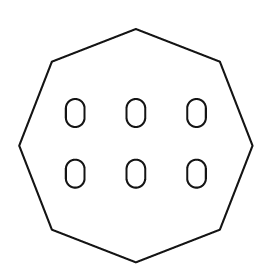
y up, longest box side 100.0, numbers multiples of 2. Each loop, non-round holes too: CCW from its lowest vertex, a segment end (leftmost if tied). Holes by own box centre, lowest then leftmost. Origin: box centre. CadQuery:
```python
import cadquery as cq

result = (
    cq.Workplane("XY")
    .moveTo(0.0, -50.0)
    .lineTo(36.0, -36.0)
    .lineTo(50.0, 0.0)
    .lineTo(36.0, 36.0)
    .lineTo(0.0, 50.0)
    .lineTo(-36.0, 36.0)
    .lineTo(-50.0, 0.0)
    .lineTo(-36.0, -36.0)
    .close()
    .moveTo(-30.0, -14.0)
    .threePointArc((-26.0, -18.0), (-22.0, -14.0))
    .lineTo(-22.0, -10.0)
    .threePointArc((-26.0, -6.0), (-30.0, -10.0))
    .close()
    .moveTo(-4.0, -14.0)
    .threePointArc((0.0, -18.0), (4.0, -14.0))
    .lineTo(4.0, -10.0)
    .threePointArc((0.0, -6.0), (-4.0, -10.0))
    .close()
    .moveTo(22.0, -14.0)
    .threePointArc((26.0, -18.0), (30.0, -14.0))
    .lineTo(30.0, -10.0)
    .threePointArc((26.0, -6.0), (22.0, -10.0))
    .close()
    .moveTo(-30.0, 12.0)
    .threePointArc((-26.0, 8.0), (-22.0, 12.0))
    .lineTo(-22.0, 16.0)
    .threePointArc((-26.0, 20.0), (-30.0, 16.0))
    .close()
    .moveTo(-4.0, 12.0)
    .threePointArc((0.0, 8.0), (4.0, 12.0))
    .lineTo(4.0, 16.0)
    .threePointArc((0.0, 20.0), (-4.0, 16.0))
    .close()
    .moveTo(22.0, 12.0)
    .threePointArc((26.0, 8.0), (30.0, 12.0))
    .lineTo(30.0, 16.0)
    .threePointArc((26.0, 20.0), (22.0, 16.0))
    .close()
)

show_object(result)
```